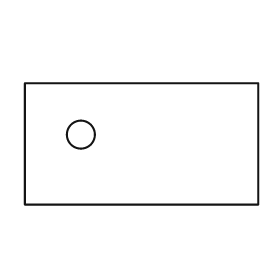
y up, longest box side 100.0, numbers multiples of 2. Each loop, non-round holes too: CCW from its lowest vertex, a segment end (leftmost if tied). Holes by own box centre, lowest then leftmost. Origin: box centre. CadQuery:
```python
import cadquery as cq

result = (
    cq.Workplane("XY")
    .moveTo(-50.0, -26.0)
    .lineTo(50.0, -26.0)
    .lineTo(50.0, 26.0)
    .lineTo(-50.0, 26.0)
    .close()
    .moveTo(-26.0, 4.0)
    .circle(6.0)
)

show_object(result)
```